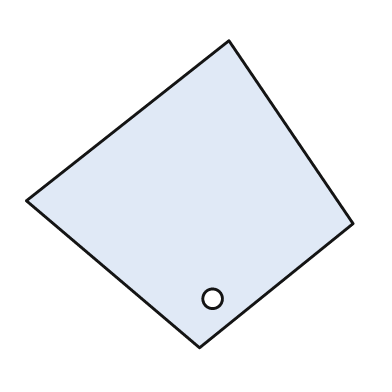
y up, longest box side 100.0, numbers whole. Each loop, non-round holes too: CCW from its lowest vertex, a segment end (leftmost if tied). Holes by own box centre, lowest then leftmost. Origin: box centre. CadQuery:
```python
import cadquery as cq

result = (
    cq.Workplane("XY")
    .moveTo(3.0, -47.0)
    .lineTo(50.0, -9.0)
    .lineTo(12.0, 47.0)
    .lineTo(-50.0, -2.0)
    .close()
    .moveTo(7.0, -32.0)
    .circle(3.0)
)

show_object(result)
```